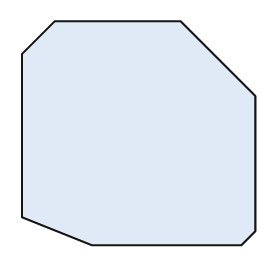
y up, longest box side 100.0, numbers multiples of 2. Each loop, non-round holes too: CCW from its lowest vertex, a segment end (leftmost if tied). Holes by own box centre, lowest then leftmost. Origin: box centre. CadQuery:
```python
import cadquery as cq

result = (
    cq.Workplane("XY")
    .moveTo(-20.0, -48.0)
    .lineTo(44.0, -48.0)
    .lineTo(50.0, -42.0)
    .lineTo(50.0, 16.0)
    .lineTo(18.0, 48.0)
    .lineTo(-36.0, 48.0)
    .lineTo(-50.0, 34.0)
    .lineTo(-50.0, -36.0)
    .close()
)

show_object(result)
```